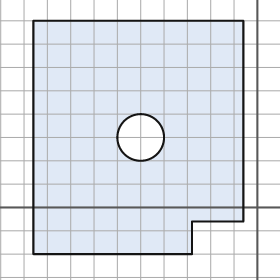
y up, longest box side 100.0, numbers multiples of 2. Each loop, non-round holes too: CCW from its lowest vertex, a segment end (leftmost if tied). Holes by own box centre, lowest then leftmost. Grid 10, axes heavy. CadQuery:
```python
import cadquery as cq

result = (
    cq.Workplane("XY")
    .moveTo(-96.0, -20.0)
    .lineTo(-28.0, -20.0)
    .lineTo(-28.0, -6.0)
    .lineTo(-6.0, -6.0)
    .lineTo(-6.0, 80.0)
    .lineTo(-96.0, 80.0)
    .close()
    .moveTo(-50.0, 30.0)
    .circle(10.0)
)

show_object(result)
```